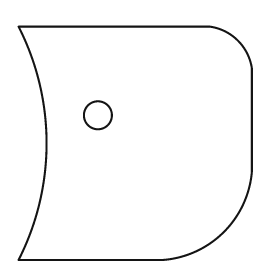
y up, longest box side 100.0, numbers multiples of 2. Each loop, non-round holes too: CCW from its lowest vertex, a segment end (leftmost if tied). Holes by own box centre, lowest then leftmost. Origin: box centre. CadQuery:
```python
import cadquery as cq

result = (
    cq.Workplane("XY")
    .moveTo(-50.0, -50.0)
    .lineTo(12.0, -50.0)
    .threePointArc((38.0, -38.0), (50.0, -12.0))
    .lineTo(50.0, 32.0)
    .threePointArc((44.0, 44.0), (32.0, 50.0))
    .lineTo(-50.0, 50.0)
    .threePointArc((-38.0, 0.0), (-50.0, -50.0))
    .close()
    .moveTo(-16.0, 12.0)
    .circle(6.0)
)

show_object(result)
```